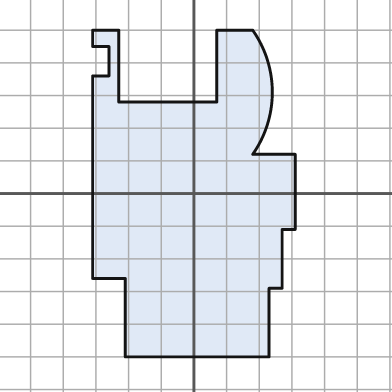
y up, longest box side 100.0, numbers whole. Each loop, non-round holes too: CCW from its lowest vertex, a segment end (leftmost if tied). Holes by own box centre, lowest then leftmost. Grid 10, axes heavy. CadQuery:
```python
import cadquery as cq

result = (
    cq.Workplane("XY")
    .moveTo(-21.0, -50.0)
    .lineTo(23.0, -50.0)
    .lineTo(23.0, -29.0)
    .lineTo(27.0, -29.0)
    .lineTo(27.0, -11.0)
    .lineTo(31.0, -11.0)
    .lineTo(31.0, 12.0)
    .lineTo(18.0, 12.0)
    .threePointArc((24.0, 31.0), (18.0, 50.0))
    .lineTo(7.0, 50.0)
    .lineTo(7.0, 28.0)
    .lineTo(-23.0, 28.0)
    .lineTo(-23.0, 50.0)
    .lineTo(-31.0, 50.0)
    .lineTo(-31.0, 45.0)
    .lineTo(-26.0, 45.0)
    .lineTo(-26.0, 36.0)
    .lineTo(-31.0, 36.0)
    .lineTo(-31.0, -26.0)
    .lineTo(-21.0, -26.0)
    .close()
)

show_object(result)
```